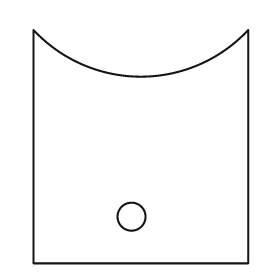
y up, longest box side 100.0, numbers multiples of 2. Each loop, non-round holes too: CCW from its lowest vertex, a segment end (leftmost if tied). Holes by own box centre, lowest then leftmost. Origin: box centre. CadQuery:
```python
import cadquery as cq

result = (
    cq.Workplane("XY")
    .moveTo(-46.0, -50.0)
    .lineTo(46.0, -50.0)
    .lineTo(46.0, 50.0)
    .threePointArc((0.0, 30.0), (-46.0, 50.0))
    .close()
    .moveTo(-4.0, -30.0)
    .circle(6.0)
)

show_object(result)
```